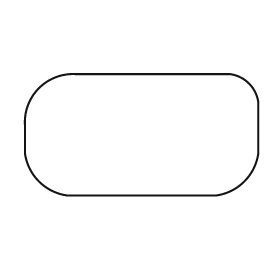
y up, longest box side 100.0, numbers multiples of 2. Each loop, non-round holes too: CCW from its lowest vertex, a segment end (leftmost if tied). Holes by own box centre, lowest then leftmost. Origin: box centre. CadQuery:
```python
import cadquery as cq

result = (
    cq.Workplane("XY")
    .moveTo(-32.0, -26.0)
    .lineTo(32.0, -26.0)
    .threePointArc((44.0, -20.0), (50.0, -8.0))
    .lineTo(50.0, 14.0)
    .threePointArc((46.0, 22.0), (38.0, 26.0))
    .lineTo(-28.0, 26.0)
    .threePointArc((-44.0, 20.0), (-50.0, 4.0))
    .lineTo(-50.0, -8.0)
    .threePointArc((-44.0, -20.0), (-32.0, -26.0))
    .close()
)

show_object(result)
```